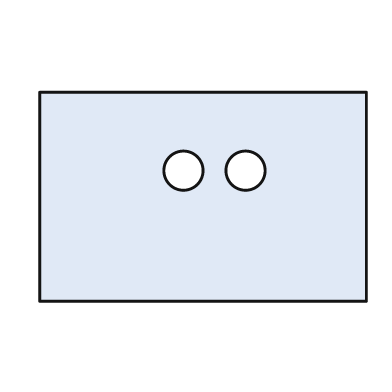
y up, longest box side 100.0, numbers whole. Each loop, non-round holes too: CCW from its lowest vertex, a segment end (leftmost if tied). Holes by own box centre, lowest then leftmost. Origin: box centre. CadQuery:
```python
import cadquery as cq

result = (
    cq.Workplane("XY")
    .moveTo(-50.0, -32.0)
    .lineTo(50.0, -32.0)
    .lineTo(50.0, 32.0)
    .lineTo(-50.0, 32.0)
    .close()
    .moveTo(-6.0, 8.0)
    .circle(6.0)
    .moveTo(13.0, 8.0)
    .circle(6.0)
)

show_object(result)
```